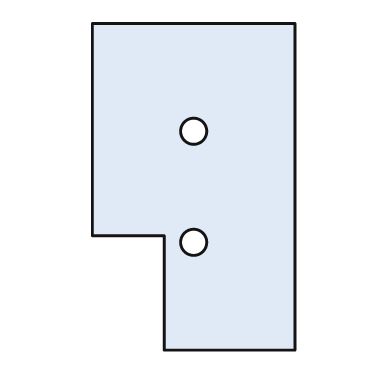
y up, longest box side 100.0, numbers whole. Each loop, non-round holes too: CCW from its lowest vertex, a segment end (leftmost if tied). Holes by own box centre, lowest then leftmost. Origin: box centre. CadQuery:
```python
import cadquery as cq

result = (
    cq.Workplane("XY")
    .moveTo(-9.0, -50.0)
    .lineTo(31.0, -50.0)
    .lineTo(31.0, 50.0)
    .lineTo(-31.0, 50.0)
    .lineTo(-31.0, -15.0)
    .lineTo(-9.0, -15.0)
    .close()
    .moveTo(0.0, -17.0)
    .circle(4.0)
    .moveTo(0.0, 17.0)
    .circle(4.0)
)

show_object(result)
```